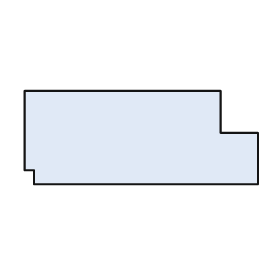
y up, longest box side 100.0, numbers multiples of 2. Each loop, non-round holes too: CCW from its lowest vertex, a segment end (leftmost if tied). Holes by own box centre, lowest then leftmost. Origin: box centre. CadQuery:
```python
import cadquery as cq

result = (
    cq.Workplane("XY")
    .moveTo(-46.0, -20.0)
    .lineTo(50.0, -20.0)
    .lineTo(50.0, 2.0)
    .lineTo(34.0, 2.0)
    .lineTo(34.0, 20.0)
    .lineTo(-50.0, 20.0)
    .lineTo(-50.0, -14.0)
    .lineTo(-46.0, -14.0)
    .close()
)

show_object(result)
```